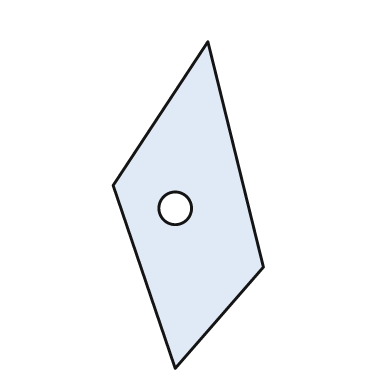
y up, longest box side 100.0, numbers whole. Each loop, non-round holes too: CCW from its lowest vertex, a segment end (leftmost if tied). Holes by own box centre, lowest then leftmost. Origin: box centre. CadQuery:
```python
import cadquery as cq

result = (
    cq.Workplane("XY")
    .moveTo(-4.0, -50.0)
    .lineTo(23.0, -19.0)
    .lineTo(6.0, 50.0)
    .lineTo(-23.0, 6.0)
    .close()
    .moveTo(-4.0, -1.0)
    .circle(5.0)
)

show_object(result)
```